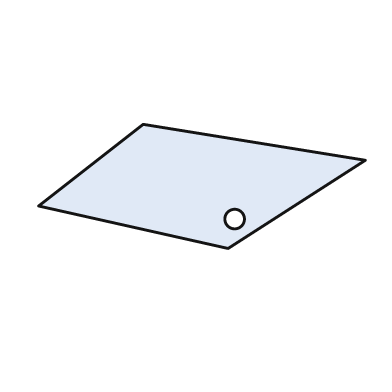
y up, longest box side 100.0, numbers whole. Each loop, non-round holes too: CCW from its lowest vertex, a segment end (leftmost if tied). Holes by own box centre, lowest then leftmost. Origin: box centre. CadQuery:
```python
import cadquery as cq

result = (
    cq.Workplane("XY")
    .moveTo(8.0, -19.0)
    .lineTo(50.0, 8.0)
    .lineTo(-18.0, 19.0)
    .lineTo(-50.0, -6.0)
    .close()
    .moveTo(10.0, -10.0)
    .circle(3.0)
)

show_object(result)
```